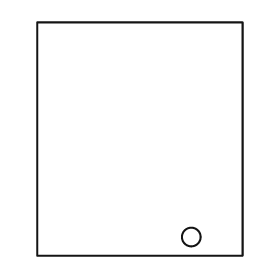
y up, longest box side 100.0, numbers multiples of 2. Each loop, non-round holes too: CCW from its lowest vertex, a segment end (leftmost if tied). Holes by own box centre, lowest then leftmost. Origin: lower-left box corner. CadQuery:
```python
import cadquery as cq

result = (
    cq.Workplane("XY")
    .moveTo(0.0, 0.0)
    .lineTo(88.0, 0.0)
    .lineTo(88.0, 100.0)
    .lineTo(0.0, 100.0)
    .close()
    .moveTo(66.0, 8.0)
    .circle(4.0)
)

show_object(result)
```